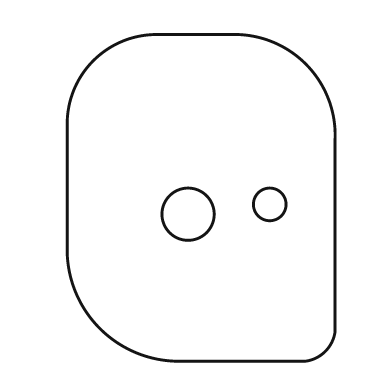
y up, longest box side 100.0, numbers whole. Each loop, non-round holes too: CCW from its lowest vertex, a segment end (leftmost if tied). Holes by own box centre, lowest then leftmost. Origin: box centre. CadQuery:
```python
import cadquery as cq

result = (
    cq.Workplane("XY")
    .moveTo(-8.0, -50.0)
    .lineTo(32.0, -50.0)
    .threePointArc((38.0, -47.0), (41.0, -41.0))
    .lineTo(41.0, 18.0)
    .threePointArc((32.0, 41.0), (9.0, 50.0))
    .lineTo(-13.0, 50.0)
    .threePointArc((-33.0, 42.0), (-41.0, 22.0))
    .lineTo(-41.0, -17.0)
    .threePointArc((-31.0, -40.0), (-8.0, -50.0))
    .close()
    .moveTo(-4.0, -5.0)
    .circle(8.0)
    .moveTo(21.0, -2.0)
    .circle(5.0)
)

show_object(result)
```